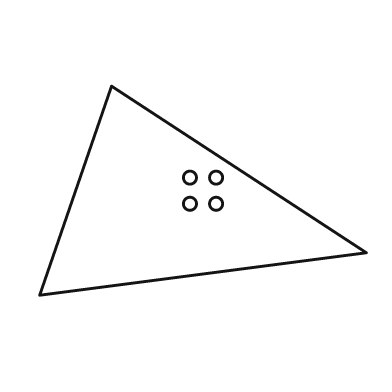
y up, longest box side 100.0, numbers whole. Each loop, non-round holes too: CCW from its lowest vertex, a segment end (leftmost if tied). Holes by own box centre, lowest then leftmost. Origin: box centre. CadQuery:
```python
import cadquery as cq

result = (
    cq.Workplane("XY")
    .moveTo(-50.0, -32.0)
    .lineTo(50.0, -19.0)
    .lineTo(-28.0, 32.0)
    .close()
    .moveTo(-4.0, -4.0)
    .circle(2.0)
    .moveTo(4.0, -4.0)
    .circle(2.0)
    .moveTo(-4.0, 4.0)
    .circle(2.0)
    .moveTo(4.0, 4.0)
    .circle(2.0)
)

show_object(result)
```